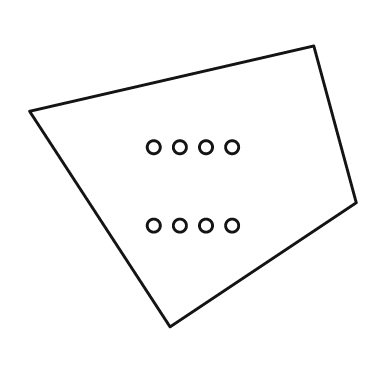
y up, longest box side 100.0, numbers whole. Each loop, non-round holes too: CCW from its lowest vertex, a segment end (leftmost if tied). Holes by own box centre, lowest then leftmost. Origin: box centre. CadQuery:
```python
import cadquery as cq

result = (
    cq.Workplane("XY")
    .moveTo(-7.0, -43.0)
    .lineTo(50.0, -5.0)
    .lineTo(37.0, 43.0)
    .lineTo(-50.0, 23.0)
    .close()
    .moveTo(-12.0, -12.0)
    .circle(2.0)
    .moveTo(-4.0, -12.0)
    .circle(2.0)
    .moveTo(4.0, -12.0)
    .circle(2.0)
    .moveTo(12.0, -12.0)
    .circle(2.0)
    .moveTo(-12.0, 12.0)
    .circle(2.0)
    .moveTo(-4.0, 12.0)
    .circle(2.0)
    .moveTo(4.0, 12.0)
    .circle(2.0)
    .moveTo(12.0, 12.0)
    .circle(2.0)
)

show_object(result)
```